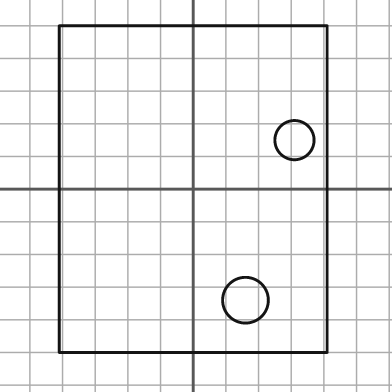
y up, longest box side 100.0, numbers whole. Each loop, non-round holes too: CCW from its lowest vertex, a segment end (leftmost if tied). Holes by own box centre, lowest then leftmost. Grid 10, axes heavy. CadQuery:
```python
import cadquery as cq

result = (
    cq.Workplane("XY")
    .moveTo(-41.0, -50.0)
    .lineTo(41.0, -50.0)
    .lineTo(41.0, 50.0)
    .lineTo(-41.0, 50.0)
    .close()
    .moveTo(16.0, -34.0)
    .circle(7.0)
    .moveTo(31.0, 15.0)
    .circle(6.0)
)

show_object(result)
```